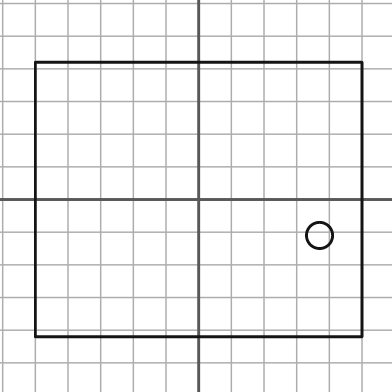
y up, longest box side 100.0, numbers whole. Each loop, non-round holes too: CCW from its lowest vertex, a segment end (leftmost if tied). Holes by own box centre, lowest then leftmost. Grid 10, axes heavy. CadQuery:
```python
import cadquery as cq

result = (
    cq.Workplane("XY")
    .moveTo(-50.0, -42.0)
    .lineTo(50.0, -42.0)
    .lineTo(50.0, 42.0)
    .lineTo(-50.0, 42.0)
    .close()
    .moveTo(37.0, -11.0)
    .circle(4.0)
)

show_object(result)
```